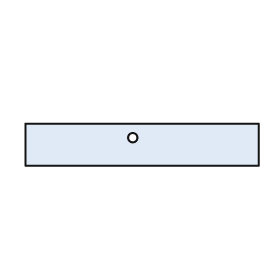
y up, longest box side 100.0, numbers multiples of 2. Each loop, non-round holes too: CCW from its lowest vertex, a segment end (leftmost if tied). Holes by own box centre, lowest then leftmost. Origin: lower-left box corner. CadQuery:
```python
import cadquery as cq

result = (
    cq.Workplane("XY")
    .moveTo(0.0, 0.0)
    .lineTo(100.0, 0.0)
    .lineTo(100.0, 18.0)
    .lineTo(0.0, 18.0)
    .close()
    .moveTo(46.0, 12.0)
    .circle(2.0)
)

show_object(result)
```